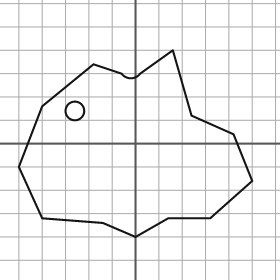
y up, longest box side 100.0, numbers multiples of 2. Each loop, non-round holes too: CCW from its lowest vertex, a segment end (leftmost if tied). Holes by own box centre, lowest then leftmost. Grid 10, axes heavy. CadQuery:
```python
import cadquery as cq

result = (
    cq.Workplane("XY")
    .moveTo(0.0, -40.0)
    .lineTo(14.0, -32.0)
    .lineTo(32.0, -32.0)
    .lineTo(50.0, -16.0)
    .lineTo(42.0, 4.0)
    .lineTo(24.0, 12.0)
    .lineTo(16.0, 40.0)
    .lineTo(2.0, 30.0)
    .threePointArc((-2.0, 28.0), (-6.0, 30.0))
    .lineTo(-18.0, 34.0)
    .lineTo(-40.0, 16.0)
    .lineTo(-50.0, -10.0)
    .lineTo(-40.0, -32.0)
    .lineTo(-14.0, -34.0)
    .close()
    .moveTo(-26.0, 14.0)
    .circle(4.0)
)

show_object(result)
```